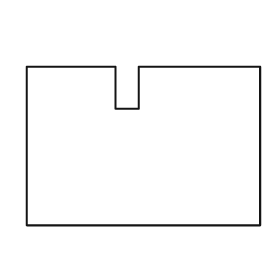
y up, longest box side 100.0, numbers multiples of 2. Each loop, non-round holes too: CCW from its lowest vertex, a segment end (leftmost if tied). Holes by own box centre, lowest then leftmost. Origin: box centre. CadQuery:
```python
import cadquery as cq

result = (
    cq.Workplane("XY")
    .moveTo(-50.0, -34.0)
    .lineTo(50.0, -34.0)
    .lineTo(50.0, 34.0)
    .lineTo(-2.0, 34.0)
    .lineTo(-2.0, 16.0)
    .lineTo(-12.0, 16.0)
    .lineTo(-12.0, 34.0)
    .lineTo(-50.0, 34.0)
    .close()
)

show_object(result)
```